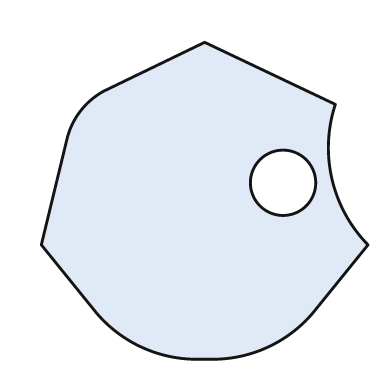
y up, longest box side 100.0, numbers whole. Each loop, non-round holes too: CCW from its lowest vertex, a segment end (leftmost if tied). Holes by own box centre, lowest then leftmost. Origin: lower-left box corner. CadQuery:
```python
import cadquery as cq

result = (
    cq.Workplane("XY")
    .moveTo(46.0, 0.0)
    .lineTo(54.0, 0.0)
    .threePointArc((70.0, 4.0), (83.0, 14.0))
    .lineTo(100.0, 35.0)
    .threePointArc((89.0, 55.0), (90.0, 78.0))
    .lineTo(50.0, 97.0)
    .lineTo(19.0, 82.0)
    .threePointArc((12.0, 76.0), (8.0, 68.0))
    .lineTo(0.0, 35.0)
    .lineTo(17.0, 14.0)
    .threePointArc((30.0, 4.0), (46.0, 0.0))
    .close()
    .moveTo(74.0, 54.0)
    .circle(10.0)
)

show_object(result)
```